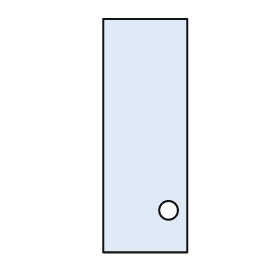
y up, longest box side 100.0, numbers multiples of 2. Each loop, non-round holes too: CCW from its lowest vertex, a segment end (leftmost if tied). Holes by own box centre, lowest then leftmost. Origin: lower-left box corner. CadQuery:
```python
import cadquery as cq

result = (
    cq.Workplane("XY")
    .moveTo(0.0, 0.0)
    .lineTo(36.0, 0.0)
    .lineTo(36.0, 100.0)
    .lineTo(0.0, 100.0)
    .close()
    .moveTo(28.0, 18.0)
    .circle(4.0)
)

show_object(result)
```